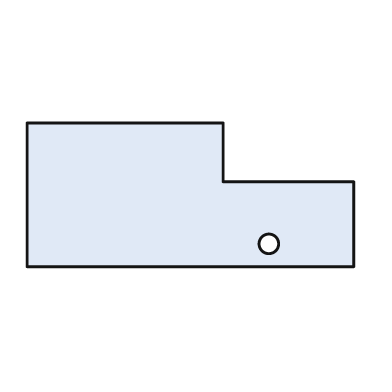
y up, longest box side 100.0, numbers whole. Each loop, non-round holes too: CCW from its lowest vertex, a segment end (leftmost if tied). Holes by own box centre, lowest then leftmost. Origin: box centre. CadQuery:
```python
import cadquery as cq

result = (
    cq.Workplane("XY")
    .moveTo(-50.0, -22.0)
    .lineTo(50.0, -22.0)
    .lineTo(50.0, 4.0)
    .lineTo(10.0, 4.0)
    .lineTo(10.0, 22.0)
    .lineTo(-50.0, 22.0)
    .close()
    .moveTo(24.0, -15.0)
    .circle(3.0)
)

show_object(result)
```